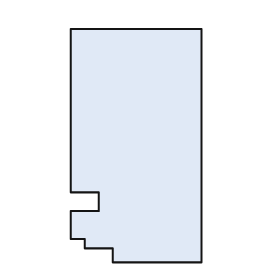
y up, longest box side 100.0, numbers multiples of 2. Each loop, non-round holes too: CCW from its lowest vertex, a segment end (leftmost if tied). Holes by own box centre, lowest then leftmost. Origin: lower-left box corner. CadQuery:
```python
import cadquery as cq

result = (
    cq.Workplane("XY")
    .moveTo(18.0, 0.0)
    .lineTo(56.0, 0.0)
    .lineTo(56.0, 100.0)
    .lineTo(0.0, 100.0)
    .lineTo(0.0, 30.0)
    .lineTo(12.0, 30.0)
    .lineTo(12.0, 22.0)
    .lineTo(0.0, 22.0)
    .lineTo(0.0, 10.0)
    .lineTo(6.0, 10.0)
    .lineTo(6.0, 6.0)
    .lineTo(18.0, 6.0)
    .close()
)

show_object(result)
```